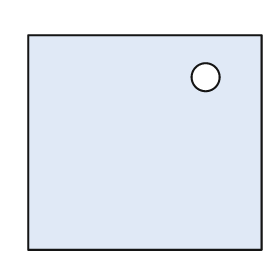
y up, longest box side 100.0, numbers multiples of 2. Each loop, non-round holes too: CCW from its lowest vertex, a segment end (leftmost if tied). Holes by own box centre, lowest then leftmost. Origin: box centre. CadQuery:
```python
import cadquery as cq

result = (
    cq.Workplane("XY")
    .moveTo(-50.0, -46.0)
    .lineTo(50.0, -46.0)
    .lineTo(50.0, 46.0)
    .lineTo(-50.0, 46.0)
    .close()
    .moveTo(26.0, 28.0)
    .circle(6.0)
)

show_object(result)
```